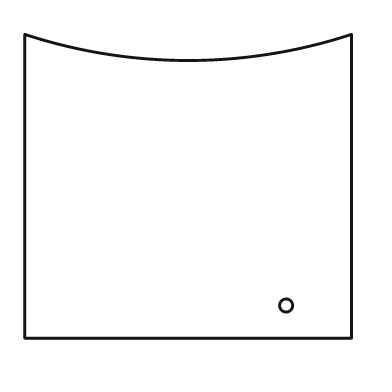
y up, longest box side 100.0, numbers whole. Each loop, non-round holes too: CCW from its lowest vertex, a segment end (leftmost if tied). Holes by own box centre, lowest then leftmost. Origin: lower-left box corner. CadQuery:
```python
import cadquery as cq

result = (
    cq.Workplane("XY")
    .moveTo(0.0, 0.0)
    .lineTo(100.0, 0.0)
    .lineTo(100.0, 93.0)
    .threePointArc((50.0, 85.0), (0.0, 93.0))
    .close()
    .moveTo(80.0, 10.0)
    .circle(2.0)
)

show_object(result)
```